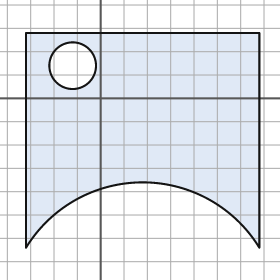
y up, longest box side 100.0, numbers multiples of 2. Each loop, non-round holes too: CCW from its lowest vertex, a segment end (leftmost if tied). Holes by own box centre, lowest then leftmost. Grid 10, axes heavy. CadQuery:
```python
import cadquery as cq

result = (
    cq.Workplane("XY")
    .moveTo(-32.0, -64.0)
    .threePointArc((18.0, -36.0), (68.0, -64.0))
    .lineTo(68.0, 28.0)
    .lineTo(-32.0, 28.0)
    .close()
    .moveTo(-12.0, 14.0)
    .circle(10.0)
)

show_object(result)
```